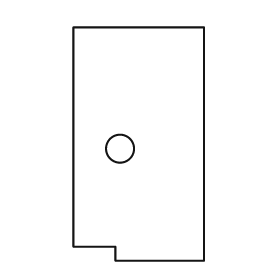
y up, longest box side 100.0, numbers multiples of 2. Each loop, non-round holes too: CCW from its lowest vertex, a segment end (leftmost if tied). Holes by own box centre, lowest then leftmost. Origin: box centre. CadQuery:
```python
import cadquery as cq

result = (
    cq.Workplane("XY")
    .moveTo(-10.0, -50.0)
    .lineTo(28.0, -50.0)
    .lineTo(28.0, 50.0)
    .lineTo(-28.0, 50.0)
    .lineTo(-28.0, -44.0)
    .lineTo(-10.0, -44.0)
    .close()
    .moveTo(-8.0, -2.0)
    .circle(6.0)
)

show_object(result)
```